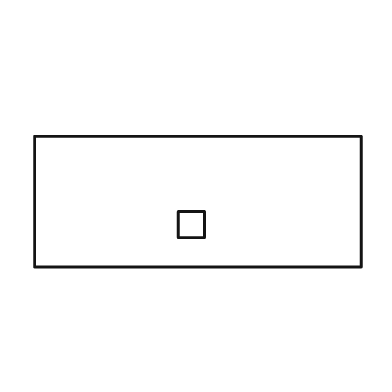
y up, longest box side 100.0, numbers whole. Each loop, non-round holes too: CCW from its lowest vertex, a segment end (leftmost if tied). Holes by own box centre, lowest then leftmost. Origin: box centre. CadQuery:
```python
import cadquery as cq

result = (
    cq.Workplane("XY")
    .moveTo(-50.0, -20.0)
    .lineTo(50.0, -20.0)
    .lineTo(50.0, 20.0)
    .lineTo(-50.0, 20.0)
    .close()
    .moveTo(-6.0, -11.0)
    .lineTo(2.0, -11.0)
    .lineTo(2.0, -3.0)
    .lineTo(-6.0, -3.0)
    .close()
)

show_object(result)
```